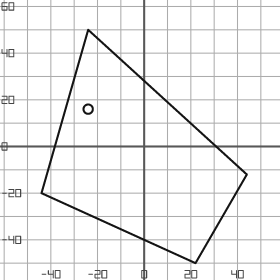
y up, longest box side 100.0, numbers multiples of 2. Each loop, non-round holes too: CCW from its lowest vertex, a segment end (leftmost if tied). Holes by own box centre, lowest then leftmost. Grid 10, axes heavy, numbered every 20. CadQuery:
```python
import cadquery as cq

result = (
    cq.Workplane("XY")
    .moveTo(22.0, -50.0)
    .lineTo(44.0, -12.0)
    .lineTo(-24.0, 50.0)
    .lineTo(-44.0, -20.0)
    .close()
    .moveTo(-24.0, 16.0)
    .circle(2.0)
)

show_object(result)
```